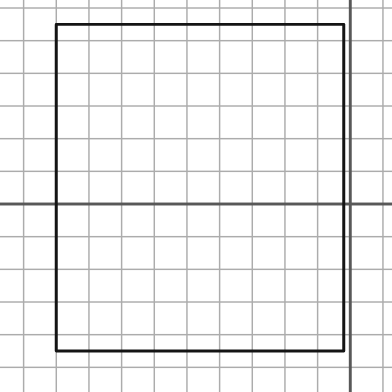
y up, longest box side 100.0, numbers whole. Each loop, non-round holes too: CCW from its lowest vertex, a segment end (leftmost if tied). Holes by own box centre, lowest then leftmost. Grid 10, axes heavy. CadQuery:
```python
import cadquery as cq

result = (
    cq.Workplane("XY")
    .moveTo(-90.0, -45.0)
    .lineTo(-2.0, -45.0)
    .lineTo(-2.0, 55.0)
    .lineTo(-90.0, 55.0)
    .close()
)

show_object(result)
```